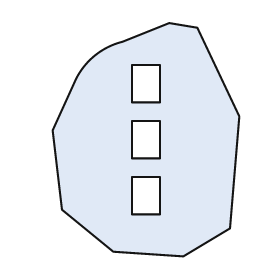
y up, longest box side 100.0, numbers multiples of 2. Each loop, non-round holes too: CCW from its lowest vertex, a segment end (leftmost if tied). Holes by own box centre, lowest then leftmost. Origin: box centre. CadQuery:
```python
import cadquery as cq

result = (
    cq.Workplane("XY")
    .moveTo(16.0, -50.0)
    .lineTo(36.0, -38.0)
    .lineTo(40.0, 10.0)
    .lineTo(22.0, 48.0)
    .lineTo(10.0, 50.0)
    .lineTo(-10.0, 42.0)
    .threePointArc((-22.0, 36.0), (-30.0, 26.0))
    .lineTo(-40.0, 4.0)
    .lineTo(-36.0, -30.0)
    .lineTo(-14.0, -48.0)
    .close()
    .moveTo(-6.0, -32.0)
    .lineTo(6.0, -32.0)
    .lineTo(6.0, -16.0)
    .lineTo(-6.0, -16.0)
    .close()
    .moveTo(-6.0, -8.0)
    .lineTo(6.0, -8.0)
    .lineTo(6.0, 8.0)
    .lineTo(-6.0, 8.0)
    .close()
    .moveTo(-6.0, 16.0)
    .lineTo(6.0, 16.0)
    .lineTo(6.0, 32.0)
    .lineTo(-6.0, 32.0)
    .close()
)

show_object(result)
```